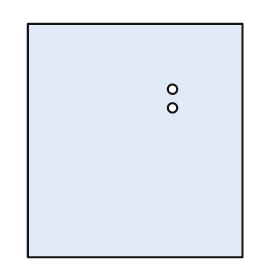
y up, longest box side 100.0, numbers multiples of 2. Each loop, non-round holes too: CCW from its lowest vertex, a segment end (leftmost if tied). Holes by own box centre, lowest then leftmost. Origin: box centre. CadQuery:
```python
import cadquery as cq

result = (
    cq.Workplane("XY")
    .moveTo(-46.0, -50.0)
    .lineTo(46.0, -50.0)
    .lineTo(46.0, 50.0)
    .lineTo(-46.0, 50.0)
    .close()
    .moveTo(16.0, 14.0)
    .circle(2.0)
    .moveTo(16.0, 22.0)
    .circle(2.0)
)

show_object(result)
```